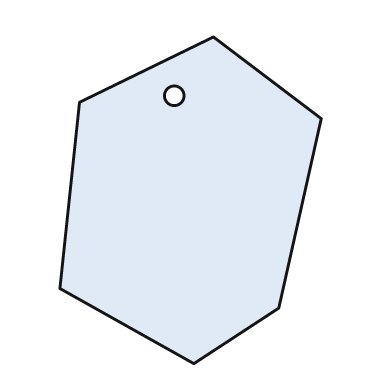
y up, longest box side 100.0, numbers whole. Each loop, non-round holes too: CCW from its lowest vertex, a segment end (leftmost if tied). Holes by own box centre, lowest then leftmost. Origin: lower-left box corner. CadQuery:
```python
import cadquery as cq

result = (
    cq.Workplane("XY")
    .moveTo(41.0, 0.0)
    .lineTo(67.0, 17.0)
    .lineTo(80.0, 75.0)
    .lineTo(47.0, 100.0)
    .lineTo(6.0, 80.0)
    .lineTo(0.0, 23.0)
    .close()
    .moveTo(35.0, 82.0)
    .circle(3.0)
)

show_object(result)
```